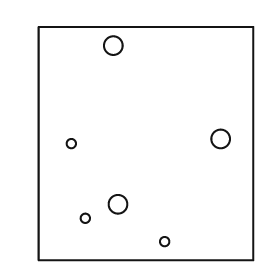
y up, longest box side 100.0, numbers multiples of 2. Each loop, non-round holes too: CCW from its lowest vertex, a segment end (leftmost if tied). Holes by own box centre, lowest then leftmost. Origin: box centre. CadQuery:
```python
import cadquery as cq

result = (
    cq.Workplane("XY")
    .moveTo(-46.0, -50.0)
    .lineTo(46.0, -50.0)
    .lineTo(46.0, 50.0)
    .lineTo(-46.0, 50.0)
    .close()
    .moveTo(8.0, -42.0)
    .circle(2.0)
    .moveTo(-26.0, -32.0)
    .circle(2.0)
    .moveTo(-12.0, -26.0)
    .circle(4.0)
    .moveTo(-32.0, 0.0)
    .circle(2.0)
    .moveTo(32.0, 2.0)
    .circle(4.0)
    .moveTo(-14.0, 42.0)
    .circle(4.0)
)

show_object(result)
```